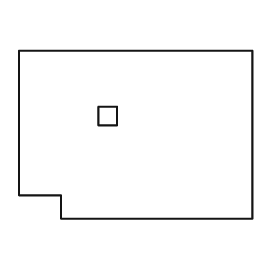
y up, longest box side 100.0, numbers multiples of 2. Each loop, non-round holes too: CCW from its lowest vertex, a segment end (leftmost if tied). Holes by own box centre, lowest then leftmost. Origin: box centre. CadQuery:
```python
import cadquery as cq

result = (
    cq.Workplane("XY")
    .moveTo(-32.0, -36.0)
    .lineTo(50.0, -36.0)
    .lineTo(50.0, 36.0)
    .lineTo(-50.0, 36.0)
    .lineTo(-50.0, -26.0)
    .lineTo(-32.0, -26.0)
    .close()
    .moveTo(-16.0, 4.0)
    .lineTo(-8.0, 4.0)
    .lineTo(-8.0, 12.0)
    .lineTo(-16.0, 12.0)
    .close()
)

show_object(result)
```